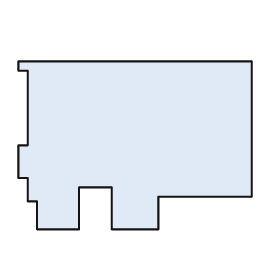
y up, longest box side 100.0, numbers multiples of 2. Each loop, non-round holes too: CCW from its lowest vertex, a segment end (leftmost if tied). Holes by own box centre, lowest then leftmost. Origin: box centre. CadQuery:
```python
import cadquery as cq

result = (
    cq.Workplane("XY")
    .moveTo(-42.0, -36.0)
    .lineTo(-24.0, -36.0)
    .lineTo(-24.0, -18.0)
    .lineTo(-10.0, -18.0)
    .lineTo(-10.0, -36.0)
    .lineTo(10.0, -36.0)
    .lineTo(10.0, -22.0)
    .lineTo(50.0, -22.0)
    .lineTo(50.0, 36.0)
    .lineTo(-50.0, 36.0)
    .lineTo(-50.0, 32.0)
    .lineTo(-46.0, 32.0)
    .lineTo(-46.0, 0.0)
    .lineTo(-50.0, 0.0)
    .lineTo(-50.0, -14.0)
    .lineTo(-46.0, -14.0)
    .lineTo(-46.0, -24.0)
    .lineTo(-42.0, -24.0)
    .close()
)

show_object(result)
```